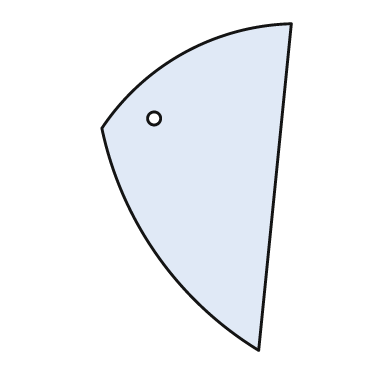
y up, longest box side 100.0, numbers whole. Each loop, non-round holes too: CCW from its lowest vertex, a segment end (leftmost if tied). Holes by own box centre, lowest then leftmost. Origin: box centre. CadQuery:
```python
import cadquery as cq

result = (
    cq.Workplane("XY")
    .moveTo(19.0, -50.0)
    .lineTo(29.0, 50.0)
    .threePointArc((-4.0, 41.0), (-29.0, 18.0))
    .threePointArc((-12.0, -21.0), (19.0, -50.0))
    .close()
    .moveTo(-13.0, 21.0)
    .circle(2.0)
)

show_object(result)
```